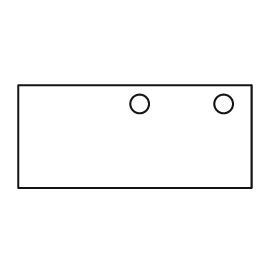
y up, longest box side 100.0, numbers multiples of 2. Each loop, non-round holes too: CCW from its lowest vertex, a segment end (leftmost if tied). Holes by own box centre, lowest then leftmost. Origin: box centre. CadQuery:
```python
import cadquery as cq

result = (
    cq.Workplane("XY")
    .moveTo(-50.0, -22.0)
    .lineTo(50.0, -22.0)
    .lineTo(50.0, 22.0)
    .lineTo(-50.0, 22.0)
    .close()
    .moveTo(2.0, 14.0)
    .circle(4.0)
    .moveTo(38.0, 14.0)
    .circle(4.0)
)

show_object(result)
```